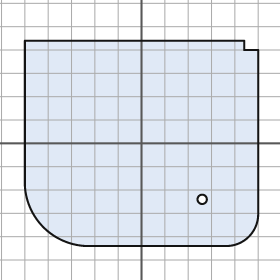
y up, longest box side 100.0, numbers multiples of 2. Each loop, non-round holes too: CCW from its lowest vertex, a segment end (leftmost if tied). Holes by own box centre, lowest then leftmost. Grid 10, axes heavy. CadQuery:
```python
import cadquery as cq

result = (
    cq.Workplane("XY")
    .moveTo(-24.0, -44.0)
    .lineTo(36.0, -44.0)
    .threePointArc((46.0, -40.0), (50.0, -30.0))
    .lineTo(50.0, 40.0)
    .lineTo(44.0, 40.0)
    .lineTo(44.0, 44.0)
    .lineTo(-50.0, 44.0)
    .lineTo(-50.0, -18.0)
    .threePointArc((-42.0, -36.0), (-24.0, -44.0))
    .close()
    .moveTo(26.0, -24.0)
    .circle(2.0)
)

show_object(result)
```